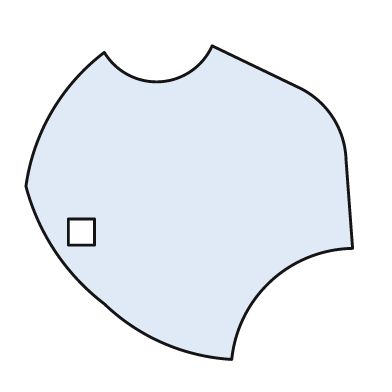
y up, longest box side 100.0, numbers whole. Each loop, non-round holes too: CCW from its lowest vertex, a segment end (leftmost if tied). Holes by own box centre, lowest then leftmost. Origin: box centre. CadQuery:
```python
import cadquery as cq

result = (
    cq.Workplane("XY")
    .moveTo(13.0, -48.0)
    .threePointArc((25.0, -24.0), (50.0, -14.0))
    .lineTo(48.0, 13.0)
    .threePointArc((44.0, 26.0), (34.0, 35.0))
    .lineTo(7.0, 48.0)
    .threePointArc((-9.0, 37.0), (-26.0, 46.0))
    .threePointArc((-42.0, 28.0), (-50.0, 5.0))
    .threePointArc((-41.0, -15.0), (-26.0, -31.0))
    .threePointArc((-8.0, -43.0), (13.0, -48.0))
    .close()
    .moveTo(-37.0, -13.0)
    .lineTo(-29.0, -13.0)
    .lineTo(-29.0, -5.0)
    .lineTo(-37.0, -5.0)
    .close()
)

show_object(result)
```